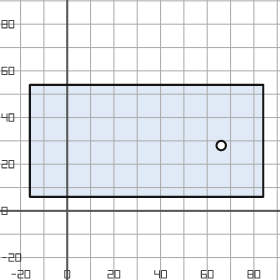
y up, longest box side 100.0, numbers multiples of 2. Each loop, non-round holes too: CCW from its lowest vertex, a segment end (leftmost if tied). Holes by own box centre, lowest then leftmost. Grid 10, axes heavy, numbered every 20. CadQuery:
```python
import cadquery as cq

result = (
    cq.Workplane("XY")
    .moveTo(-16.0, 6.0)
    .lineTo(84.0, 6.0)
    .lineTo(84.0, 54.0)
    .lineTo(-16.0, 54.0)
    .close()
    .moveTo(66.0, 28.0)
    .circle(2.0)
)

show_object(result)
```